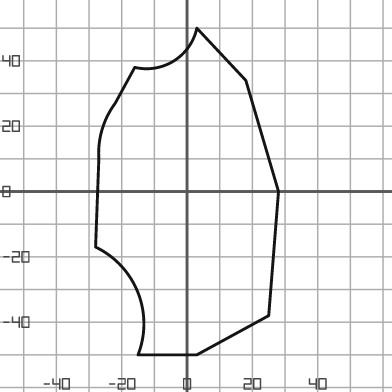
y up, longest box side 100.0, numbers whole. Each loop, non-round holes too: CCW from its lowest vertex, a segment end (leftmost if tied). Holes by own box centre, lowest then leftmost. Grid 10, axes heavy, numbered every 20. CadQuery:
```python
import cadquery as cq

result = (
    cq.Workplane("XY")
    .moveTo(-15.0, -50.0)
    .lineTo(3.0, -50.0)
    .lineTo(25.0, -38.0)
    .lineTo(28.0, 0.0)
    .lineTo(18.0, 34.0)
    .lineTo(3.0, 50.0)
    .threePointArc((-4.0, 40.0), (-16.0, 38.0))
    .lineTo(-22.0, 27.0)
    .threePointArc((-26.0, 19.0), (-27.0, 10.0))
    .lineTo(-28.0, -17.0)
    .threePointArc((-15.0, -31.0), (-15.0, -50.0))
    .close()
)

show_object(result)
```